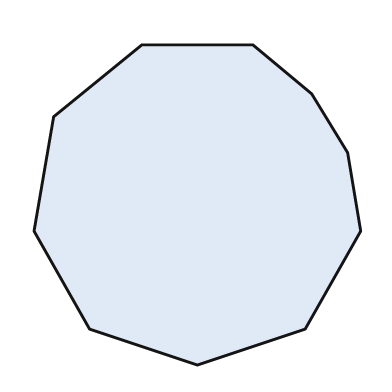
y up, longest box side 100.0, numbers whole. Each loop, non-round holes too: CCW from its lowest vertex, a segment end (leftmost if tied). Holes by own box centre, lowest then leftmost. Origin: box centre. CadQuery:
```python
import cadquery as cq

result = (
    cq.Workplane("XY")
    .moveTo(0.0, -49.0)
    .lineTo(33.0, -38.0)
    .lineTo(50.0, -8.0)
    .lineTo(46.0, 16.0)
    .lineTo(35.0, 34.0)
    .lineTo(17.0, 49.0)
    .lineTo(-17.0, 49.0)
    .lineTo(-44.0, 27.0)
    .lineTo(-50.0, -8.0)
    .lineTo(-33.0, -38.0)
    .close()
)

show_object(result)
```